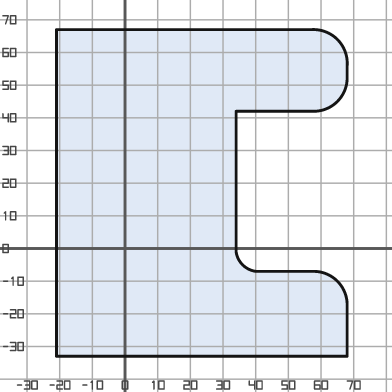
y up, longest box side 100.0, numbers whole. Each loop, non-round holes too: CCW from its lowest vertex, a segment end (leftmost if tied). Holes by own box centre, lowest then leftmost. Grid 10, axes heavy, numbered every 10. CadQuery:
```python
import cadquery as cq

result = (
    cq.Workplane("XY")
    .moveTo(-21.0, -33.0)
    .lineTo(68.0, -33.0)
    .lineTo(68.0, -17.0)
    .threePointArc((65.0, -10.0), (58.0, -7.0))
    .lineTo(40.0, -7.0)
    .threePointArc((36.0, -5.0), (34.0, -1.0))
    .lineTo(34.0, 42.0)
    .lineTo(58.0, 42.0)
    .threePointArc((65.0, 45.0), (68.0, 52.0))
    .lineTo(68.0, 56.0)
    .threePointArc((65.0, 64.0), (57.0, 67.0))
    .lineTo(-21.0, 67.0)
    .close()
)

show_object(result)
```